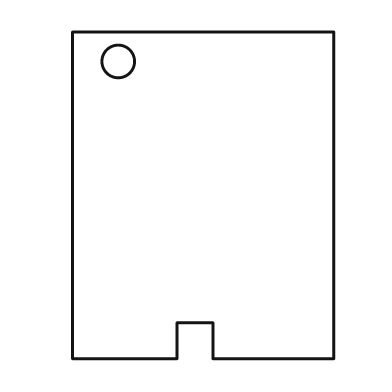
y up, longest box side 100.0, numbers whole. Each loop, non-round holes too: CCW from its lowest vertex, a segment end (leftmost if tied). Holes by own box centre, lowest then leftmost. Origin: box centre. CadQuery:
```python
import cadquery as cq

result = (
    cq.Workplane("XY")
    .moveTo(-40.0, -50.0)
    .lineTo(-8.0, -50.0)
    .lineTo(-8.0, -39.0)
    .lineTo(3.0, -39.0)
    .lineTo(3.0, -50.0)
    .lineTo(40.0, -50.0)
    .lineTo(40.0, 50.0)
    .lineTo(-40.0, 50.0)
    .close()
    .moveTo(-26.0, 41.0)
    .circle(5.0)
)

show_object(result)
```